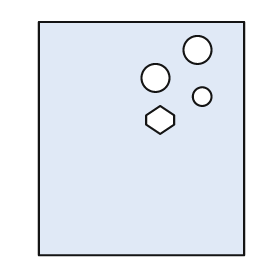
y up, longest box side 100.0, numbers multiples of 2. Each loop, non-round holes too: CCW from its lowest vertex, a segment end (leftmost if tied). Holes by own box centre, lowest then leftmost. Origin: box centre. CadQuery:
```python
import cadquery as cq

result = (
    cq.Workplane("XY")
    .moveTo(-44.0, -50.0)
    .lineTo(44.0, -50.0)
    .lineTo(44.0, 50.0)
    .lineTo(-44.0, 50.0)
    .close()
    .moveTo(8.0, 2.0)
    .lineTo(14.0, 6.0)
    .lineTo(14.0, 10.0)
    .lineTo(8.0, 14.0)
    .lineTo(2.0, 10.0)
    .lineTo(2.0, 6.0)
    .close()
    .moveTo(26.0, 18.0)
    .circle(4.0)
    .moveTo(6.0, 26.0)
    .circle(6.0)
    .moveTo(24.0, 38.0)
    .circle(6.0)
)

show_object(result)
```